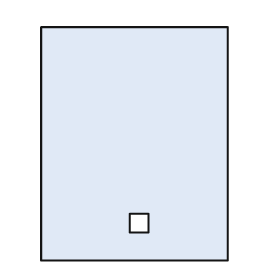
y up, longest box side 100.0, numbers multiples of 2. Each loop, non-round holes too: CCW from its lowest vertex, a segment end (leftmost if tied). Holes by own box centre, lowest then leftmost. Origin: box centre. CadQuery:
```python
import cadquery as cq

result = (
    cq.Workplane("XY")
    .moveTo(-40.0, -50.0)
    .lineTo(40.0, -50.0)
    .lineTo(40.0, 50.0)
    .lineTo(-40.0, 50.0)
    .close()
    .moveTo(-2.0, -38.0)
    .lineTo(6.0, -38.0)
    .lineTo(6.0, -30.0)
    .lineTo(-2.0, -30.0)
    .close()
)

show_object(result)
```